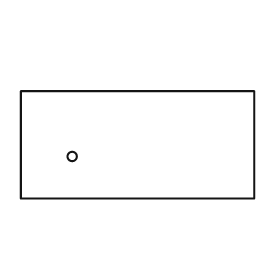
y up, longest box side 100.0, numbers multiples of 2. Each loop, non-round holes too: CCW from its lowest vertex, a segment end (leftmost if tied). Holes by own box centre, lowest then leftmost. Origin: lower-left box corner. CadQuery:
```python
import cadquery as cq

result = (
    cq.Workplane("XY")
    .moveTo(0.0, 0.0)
    .lineTo(100.0, 0.0)
    .lineTo(100.0, 46.0)
    .lineTo(0.0, 46.0)
    .close()
    .moveTo(22.0, 18.0)
    .circle(2.0)
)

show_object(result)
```